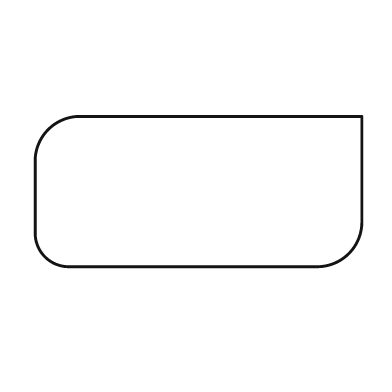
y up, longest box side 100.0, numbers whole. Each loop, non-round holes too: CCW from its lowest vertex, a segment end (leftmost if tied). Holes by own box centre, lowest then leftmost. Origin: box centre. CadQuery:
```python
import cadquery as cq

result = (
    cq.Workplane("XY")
    .moveTo(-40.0, -23.0)
    .lineTo(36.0, -23.0)
    .threePointArc((46.0, -19.0), (50.0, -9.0))
    .lineTo(50.0, 23.0)
    .lineTo(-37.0, 23.0)
    .threePointArc((-46.0, 19.0), (-50.0, 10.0))
    .lineTo(-50.0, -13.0)
    .threePointArc((-47.0, -20.0), (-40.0, -23.0))
    .close()
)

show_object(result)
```